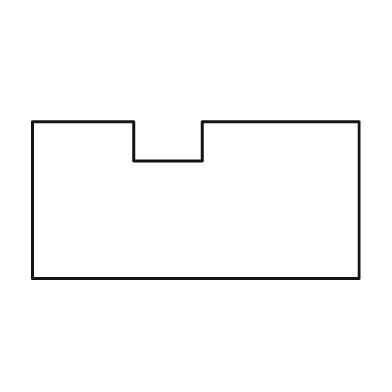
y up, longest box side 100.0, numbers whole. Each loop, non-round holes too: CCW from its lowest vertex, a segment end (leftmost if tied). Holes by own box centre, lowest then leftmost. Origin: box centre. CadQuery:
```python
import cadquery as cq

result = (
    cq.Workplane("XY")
    .moveTo(-50.0, -24.0)
    .lineTo(50.0, -24.0)
    .lineTo(50.0, 24.0)
    .lineTo(2.0, 24.0)
    .lineTo(2.0, 12.0)
    .lineTo(-19.0, 12.0)
    .lineTo(-19.0, 24.0)
    .lineTo(-50.0, 24.0)
    .close()
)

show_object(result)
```